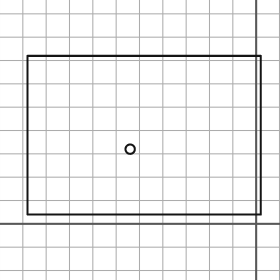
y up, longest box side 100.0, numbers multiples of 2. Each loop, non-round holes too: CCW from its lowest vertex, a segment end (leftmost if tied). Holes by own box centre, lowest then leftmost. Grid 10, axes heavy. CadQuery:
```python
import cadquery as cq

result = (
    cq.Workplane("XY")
    .moveTo(-98.0, 4.0)
    .lineTo(2.0, 4.0)
    .lineTo(2.0, 72.0)
    .lineTo(-98.0, 72.0)
    .close()
    .moveTo(-54.0, 32.0)
    .circle(2.0)
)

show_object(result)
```